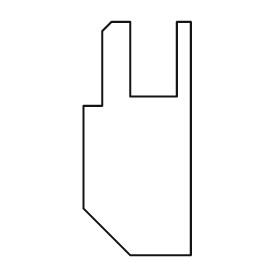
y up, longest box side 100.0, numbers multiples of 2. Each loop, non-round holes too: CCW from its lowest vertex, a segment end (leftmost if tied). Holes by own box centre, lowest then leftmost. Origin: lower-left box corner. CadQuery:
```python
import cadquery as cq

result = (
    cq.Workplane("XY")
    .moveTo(20.0, 0.0)
    .lineTo(46.0, 0.0)
    .lineTo(46.0, 100.0)
    .lineTo(40.0, 100.0)
    .lineTo(40.0, 68.0)
    .lineTo(20.0, 68.0)
    .lineTo(20.0, 100.0)
    .lineTo(12.0, 100.0)
    .lineTo(8.0, 96.0)
    .lineTo(8.0, 64.0)
    .lineTo(0.0, 64.0)
    .lineTo(0.0, 20.0)
    .close()
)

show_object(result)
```